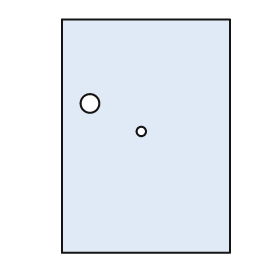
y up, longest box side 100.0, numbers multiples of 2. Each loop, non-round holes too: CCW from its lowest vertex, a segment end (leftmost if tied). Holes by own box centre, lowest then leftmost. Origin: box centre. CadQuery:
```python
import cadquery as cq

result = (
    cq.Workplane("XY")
    .moveTo(-36.0, -50.0)
    .lineTo(36.0, -50.0)
    .lineTo(36.0, 50.0)
    .lineTo(-36.0, 50.0)
    .close()
    .moveTo(-2.0, 2.0)
    .circle(2.0)
    .moveTo(-24.0, 14.0)
    .circle(4.0)
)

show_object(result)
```